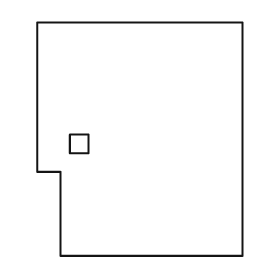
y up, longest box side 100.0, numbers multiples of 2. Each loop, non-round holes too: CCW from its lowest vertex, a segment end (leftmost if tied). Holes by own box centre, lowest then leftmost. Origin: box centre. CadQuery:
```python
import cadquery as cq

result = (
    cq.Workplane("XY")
    .moveTo(-34.0, -50.0)
    .lineTo(44.0, -50.0)
    .lineTo(44.0, 50.0)
    .lineTo(-44.0, 50.0)
    .lineTo(-44.0, -14.0)
    .lineTo(-34.0, -14.0)
    .close()
    .moveTo(-30.0, -6.0)
    .lineTo(-22.0, -6.0)
    .lineTo(-22.0, 2.0)
    .lineTo(-30.0, 2.0)
    .close()
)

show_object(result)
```